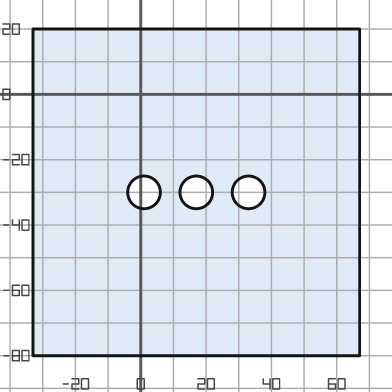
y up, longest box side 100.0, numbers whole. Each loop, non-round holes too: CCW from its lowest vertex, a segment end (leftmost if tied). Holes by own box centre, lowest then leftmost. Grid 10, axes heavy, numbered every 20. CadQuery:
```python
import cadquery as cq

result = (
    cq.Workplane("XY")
    .moveTo(-33.0, -80.0)
    .lineTo(67.0, -80.0)
    .lineTo(67.0, 20.0)
    .lineTo(-33.0, 20.0)
    .close()
    .moveTo(1.0, -30.0)
    .circle(5.0)
    .moveTo(17.0, -30.0)
    .circle(5.0)
    .moveTo(33.0, -30.0)
    .circle(5.0)
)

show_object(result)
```